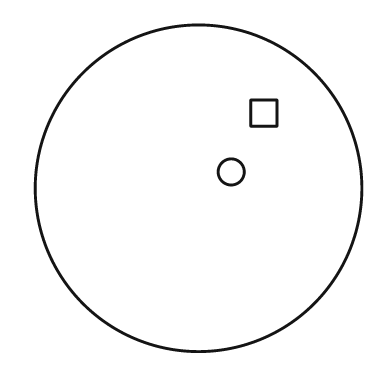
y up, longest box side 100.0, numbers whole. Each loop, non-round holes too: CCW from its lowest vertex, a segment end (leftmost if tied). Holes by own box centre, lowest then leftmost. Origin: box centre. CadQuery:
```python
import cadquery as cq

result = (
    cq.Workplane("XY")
    .moveTo(0.0, 0.0)
    .circle(50.0)
    .moveTo(10.0, 5.0)
    .circle(4.0)
    .moveTo(16.0, 19.0)
    .lineTo(24.0, 19.0)
    .lineTo(24.0, 27.0)
    .lineTo(16.0, 27.0)
    .close()
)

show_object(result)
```